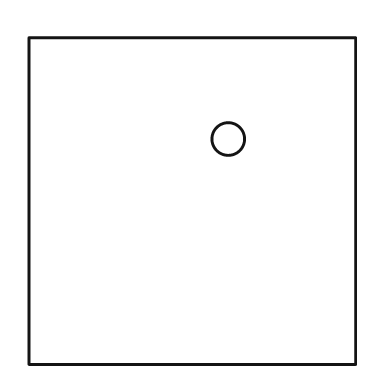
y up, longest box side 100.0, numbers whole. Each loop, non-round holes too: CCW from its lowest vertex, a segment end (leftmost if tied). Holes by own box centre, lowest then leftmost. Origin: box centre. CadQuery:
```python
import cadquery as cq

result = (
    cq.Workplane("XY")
    .moveTo(-50.0, -50.0)
    .lineTo(50.0, -50.0)
    .lineTo(50.0, 50.0)
    .lineTo(-50.0, 50.0)
    .close()
    .moveTo(11.0, 19.0)
    .circle(5.0)
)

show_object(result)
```